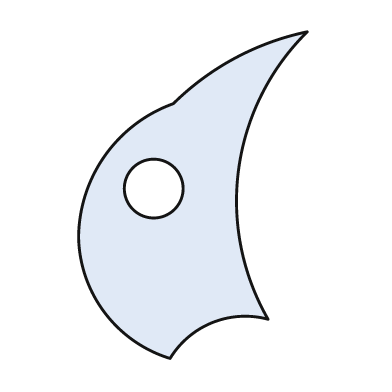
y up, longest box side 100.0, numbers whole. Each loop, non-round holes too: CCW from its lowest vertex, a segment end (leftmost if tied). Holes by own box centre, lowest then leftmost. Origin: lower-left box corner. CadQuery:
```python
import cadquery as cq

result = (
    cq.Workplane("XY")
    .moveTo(28.0, 0.0)
    .threePointArc((41.0, 11.0), (58.0, 12.0))
    .threePointArc((49.0, 58.0), (70.0, 100.0))
    .threePointArc((48.0, 92.0), (29.0, 78.0))
    .threePointArc((8.0, 62.0), (0.0, 37.0))
    .threePointArc((8.0, 14.0), (28.0, 0.0))
    .close()
    .moveTo(23.0, 52.0)
    .circle(9.0)
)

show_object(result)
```